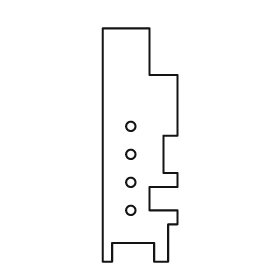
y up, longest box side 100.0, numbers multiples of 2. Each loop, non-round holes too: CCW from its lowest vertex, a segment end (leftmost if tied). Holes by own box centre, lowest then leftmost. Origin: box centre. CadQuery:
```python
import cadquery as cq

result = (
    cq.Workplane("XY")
    .moveTo(-16.0, -50.0)
    .lineTo(-12.0, -50.0)
    .lineTo(-12.0, -42.0)
    .lineTo(6.0, -42.0)
    .lineTo(6.0, -50.0)
    .lineTo(12.0, -50.0)
    .lineTo(12.0, -34.0)
    .lineTo(16.0, -34.0)
    .lineTo(16.0, -28.0)
    .lineTo(4.0, -28.0)
    .lineTo(4.0, -18.0)
    .lineTo(16.0, -18.0)
    .lineTo(16.0, -12.0)
    .lineTo(10.0, -12.0)
    .lineTo(10.0, 4.0)
    .lineTo(16.0, 4.0)
    .lineTo(16.0, 30.0)
    .lineTo(4.0, 30.0)
    .lineTo(4.0, 50.0)
    .lineTo(-16.0, 50.0)
    .close()
    .moveTo(-4.0, -28.0)
    .circle(2.0)
    .moveTo(-4.0, -16.0)
    .circle(2.0)
    .moveTo(-4.0, -4.0)
    .circle(2.0)
    .moveTo(-4.0, 8.0)
    .circle(2.0)
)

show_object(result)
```